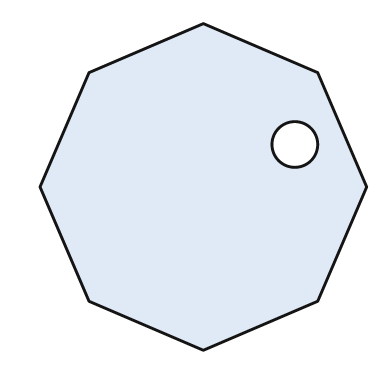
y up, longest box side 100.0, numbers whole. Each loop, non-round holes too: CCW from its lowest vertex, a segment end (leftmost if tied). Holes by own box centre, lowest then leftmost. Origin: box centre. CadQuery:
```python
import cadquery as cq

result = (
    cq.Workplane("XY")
    .moveTo(0.0, -50.0)
    .lineTo(35.0, -35.0)
    .lineTo(50.0, 0.0)
    .lineTo(35.0, 35.0)
    .lineTo(0.0, 50.0)
    .lineTo(-35.0, 35.0)
    .lineTo(-50.0, 0.0)
    .lineTo(-35.0, -35.0)
    .close()
    .moveTo(28.0, 13.0)
    .circle(7.0)
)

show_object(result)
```